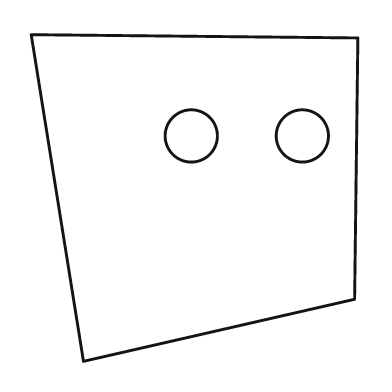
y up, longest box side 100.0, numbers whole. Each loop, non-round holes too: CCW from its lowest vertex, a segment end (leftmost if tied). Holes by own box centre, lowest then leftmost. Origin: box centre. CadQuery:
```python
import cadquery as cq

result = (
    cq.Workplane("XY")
    .moveTo(-34.0, -50.0)
    .lineTo(49.0, -31.0)
    .lineTo(50.0, 49.0)
    .lineTo(-50.0, 50.0)
    .close()
    .moveTo(-1.0, 19.0)
    .circle(8.0)
    .moveTo(33.0, 19.0)
    .circle(8.0)
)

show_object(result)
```